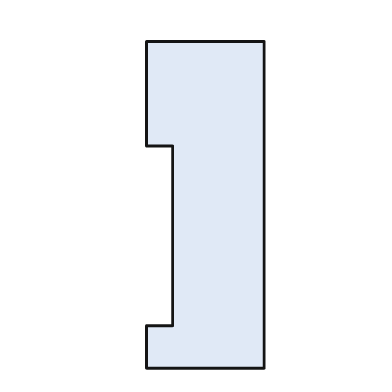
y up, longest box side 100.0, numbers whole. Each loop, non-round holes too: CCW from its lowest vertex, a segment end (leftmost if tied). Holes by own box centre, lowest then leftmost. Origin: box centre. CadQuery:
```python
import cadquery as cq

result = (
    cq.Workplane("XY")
    .moveTo(-18.0, -50.0)
    .lineTo(18.0, -50.0)
    .lineTo(18.0, 50.0)
    .lineTo(-18.0, 50.0)
    .lineTo(-18.0, 18.0)
    .lineTo(-10.0, 18.0)
    .lineTo(-10.0, -37.0)
    .lineTo(-18.0, -37.0)
    .close()
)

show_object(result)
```